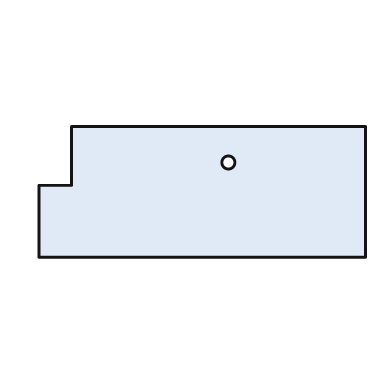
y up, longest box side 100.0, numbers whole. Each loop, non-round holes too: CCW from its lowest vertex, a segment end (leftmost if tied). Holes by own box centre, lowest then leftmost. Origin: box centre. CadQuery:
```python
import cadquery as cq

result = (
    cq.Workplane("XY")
    .moveTo(-50.0, -20.0)
    .lineTo(50.0, -20.0)
    .lineTo(50.0, 20.0)
    .lineTo(-40.0, 20.0)
    .lineTo(-40.0, 2.0)
    .lineTo(-50.0, 2.0)
    .close()
    .moveTo(8.0, 9.0)
    .circle(2.0)
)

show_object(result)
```